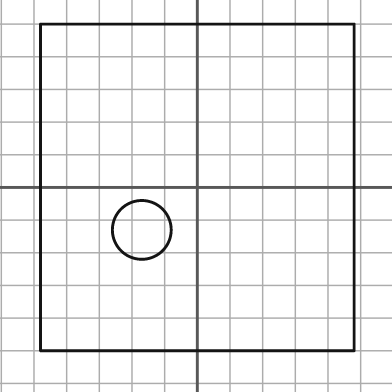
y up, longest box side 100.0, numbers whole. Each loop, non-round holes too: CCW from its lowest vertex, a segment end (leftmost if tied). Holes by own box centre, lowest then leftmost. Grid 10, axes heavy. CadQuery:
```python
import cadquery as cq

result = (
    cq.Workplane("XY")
    .moveTo(-48.0, -50.0)
    .lineTo(48.0, -50.0)
    .lineTo(48.0, 50.0)
    .lineTo(-48.0, 50.0)
    .close()
    .moveTo(-17.0, -13.0)
    .circle(9.0)
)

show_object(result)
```